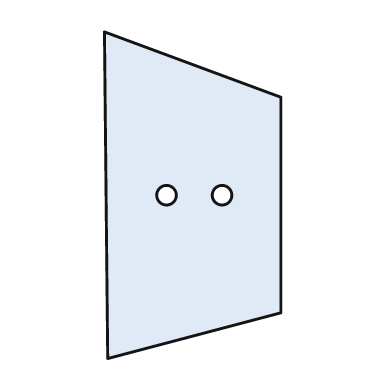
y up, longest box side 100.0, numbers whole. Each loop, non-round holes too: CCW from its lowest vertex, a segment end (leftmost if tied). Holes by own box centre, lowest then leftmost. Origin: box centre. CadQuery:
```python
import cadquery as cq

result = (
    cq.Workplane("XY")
    .moveTo(-26.0, -50.0)
    .lineTo(27.0, -36.0)
    .lineTo(27.0, 30.0)
    .lineTo(-27.0, 50.0)
    .close()
    .moveTo(-8.0, 0.0)
    .circle(3.0)
    .moveTo(9.0, 0.0)
    .circle(3.0)
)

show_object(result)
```